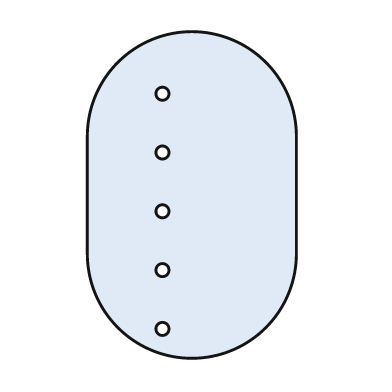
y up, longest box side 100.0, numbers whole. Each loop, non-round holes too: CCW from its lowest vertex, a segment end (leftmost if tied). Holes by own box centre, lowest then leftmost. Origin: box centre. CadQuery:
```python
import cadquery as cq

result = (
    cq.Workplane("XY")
    .moveTo(-32.0, -18.0)
    .threePointArc((0.0, -50.0), (32.0, -18.0))
    .lineTo(32.0, 18.0)
    .threePointArc((0.0, 50.0), (-32.0, 18.0))
    .close()
    .moveTo(-9.0, -41.0)
    .circle(2.0)
    .moveTo(-9.0, -23.0)
    .circle(2.0)
    .moveTo(-9.0, -5.0)
    .circle(2.0)
    .moveTo(-9.0, 13.0)
    .circle(2.0)
    .moveTo(-9.0, 31.0)
    .circle(2.0)
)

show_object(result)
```